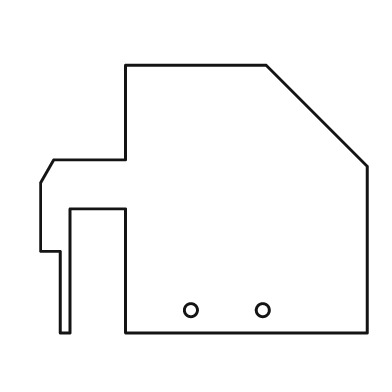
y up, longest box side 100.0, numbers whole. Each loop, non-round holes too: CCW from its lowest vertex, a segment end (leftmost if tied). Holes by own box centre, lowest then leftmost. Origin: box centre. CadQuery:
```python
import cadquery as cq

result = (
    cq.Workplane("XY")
    .moveTo(-44.0, -41.0)
    .lineTo(-41.0, -41.0)
    .lineTo(-41.0, -3.0)
    .lineTo(-24.0, -3.0)
    .lineTo(-24.0, -41.0)
    .lineTo(50.0, -41.0)
    .lineTo(50.0, 10.0)
    .lineTo(19.0, 41.0)
    .lineTo(-24.0, 41.0)
    .lineTo(-24.0, 12.0)
    .lineTo(-46.0, 12.0)
    .lineTo(-50.0, 5.0)
    .lineTo(-50.0, -16.0)
    .lineTo(-44.0, -16.0)
    .close()
    .moveTo(-4.0, -34.0)
    .circle(2.0)
    .moveTo(18.0, -34.0)
    .circle(2.0)
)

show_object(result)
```